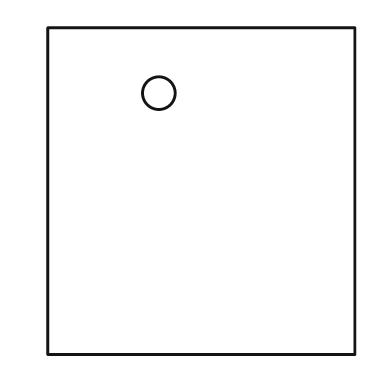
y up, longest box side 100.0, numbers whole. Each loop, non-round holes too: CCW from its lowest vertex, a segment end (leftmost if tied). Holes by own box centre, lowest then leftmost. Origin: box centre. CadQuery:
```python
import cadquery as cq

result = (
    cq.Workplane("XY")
    .moveTo(-47.0, -50.0)
    .lineTo(47.0, -50.0)
    .lineTo(47.0, 50.0)
    .lineTo(-47.0, 50.0)
    .close()
    .moveTo(-13.0, 30.0)
    .circle(5.0)
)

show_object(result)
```